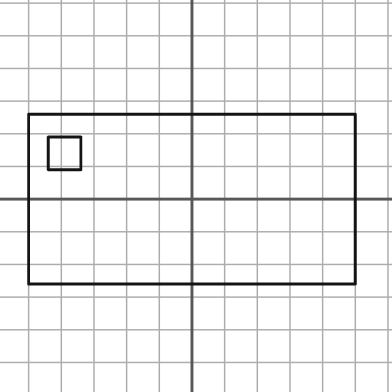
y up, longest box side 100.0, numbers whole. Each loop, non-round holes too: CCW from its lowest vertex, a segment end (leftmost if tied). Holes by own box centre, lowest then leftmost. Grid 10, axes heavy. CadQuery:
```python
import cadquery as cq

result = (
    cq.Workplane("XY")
    .moveTo(-50.0, -26.0)
    .lineTo(50.0, -26.0)
    .lineTo(50.0, 26.0)
    .lineTo(-50.0, 26.0)
    .close()
    .moveTo(-44.0, 9.0)
    .lineTo(-34.0, 9.0)
    .lineTo(-34.0, 19.0)
    .lineTo(-44.0, 19.0)
    .close()
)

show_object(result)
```